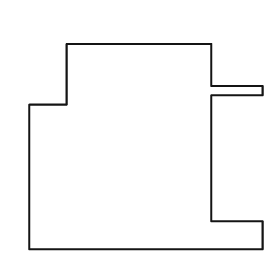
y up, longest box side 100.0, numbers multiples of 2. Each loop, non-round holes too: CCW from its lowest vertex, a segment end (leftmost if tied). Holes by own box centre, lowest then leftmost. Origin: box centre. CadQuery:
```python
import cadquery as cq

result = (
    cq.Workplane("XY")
    .moveTo(-50.0, -44.0)
    .lineTo(50.0, -44.0)
    .lineTo(50.0, -32.0)
    .lineTo(28.0, -32.0)
    .lineTo(28.0, 22.0)
    .lineTo(50.0, 22.0)
    .lineTo(50.0, 26.0)
    .lineTo(28.0, 26.0)
    .lineTo(28.0, 44.0)
    .lineTo(-34.0, 44.0)
    .lineTo(-34.0, 18.0)
    .lineTo(-50.0, 18.0)
    .close()
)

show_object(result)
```